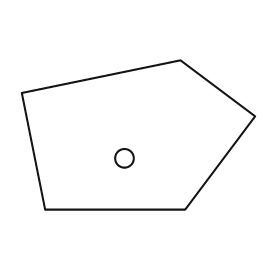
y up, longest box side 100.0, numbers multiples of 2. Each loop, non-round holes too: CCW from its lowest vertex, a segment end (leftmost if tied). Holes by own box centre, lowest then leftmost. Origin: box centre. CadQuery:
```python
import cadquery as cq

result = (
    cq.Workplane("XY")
    .moveTo(-40.0, -32.0)
    .lineTo(20.0, -32.0)
    .lineTo(50.0, 8.0)
    .lineTo(18.0, 32.0)
    .lineTo(-50.0, 18.0)
    .close()
    .moveTo(-6.0, -10.0)
    .circle(4.0)
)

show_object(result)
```